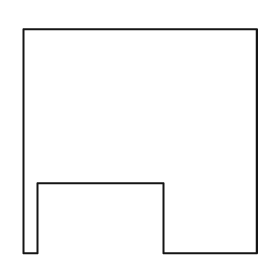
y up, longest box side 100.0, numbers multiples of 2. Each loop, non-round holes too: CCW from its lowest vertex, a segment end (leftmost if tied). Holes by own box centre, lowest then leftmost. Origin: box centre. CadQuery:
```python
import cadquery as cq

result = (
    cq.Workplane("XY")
    .moveTo(-50.0, -48.0)
    .lineTo(-44.0, -48.0)
    .lineTo(-44.0, -18.0)
    .lineTo(10.0, -18.0)
    .lineTo(10.0, -48.0)
    .lineTo(50.0, -48.0)
    .lineTo(50.0, 48.0)
    .lineTo(-50.0, 48.0)
    .close()
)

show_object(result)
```